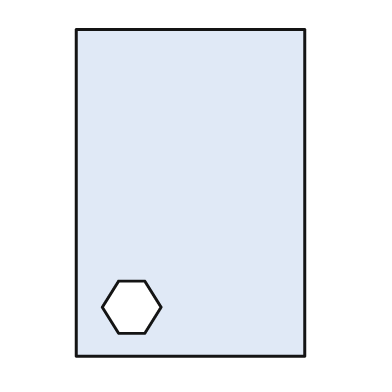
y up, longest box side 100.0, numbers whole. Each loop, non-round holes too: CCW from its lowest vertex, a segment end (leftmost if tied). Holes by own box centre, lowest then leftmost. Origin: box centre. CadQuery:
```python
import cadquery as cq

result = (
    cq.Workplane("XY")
    .moveTo(-35.0, -50.0)
    .lineTo(35.0, -50.0)
    .lineTo(35.0, 50.0)
    .lineTo(-35.0, 50.0)
    .close()
    .moveTo(-22.0, -43.0)
    .lineTo(-14.0, -43.0)
    .lineTo(-9.0, -35.0)
    .lineTo(-14.0, -27.0)
    .lineTo(-22.0, -27.0)
    .lineTo(-27.0, -35.0)
    .close()
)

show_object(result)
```